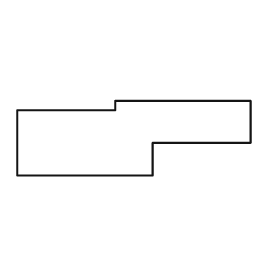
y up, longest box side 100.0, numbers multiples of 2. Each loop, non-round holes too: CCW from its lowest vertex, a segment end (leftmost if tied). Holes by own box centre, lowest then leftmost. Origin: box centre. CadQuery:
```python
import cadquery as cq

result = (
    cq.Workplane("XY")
    .moveTo(-50.0, -16.0)
    .lineTo(8.0, -16.0)
    .lineTo(8.0, -2.0)
    .lineTo(50.0, -2.0)
    .lineTo(50.0, 16.0)
    .lineTo(-8.0, 16.0)
    .lineTo(-8.0, 12.0)
    .lineTo(-50.0, 12.0)
    .close()
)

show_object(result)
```